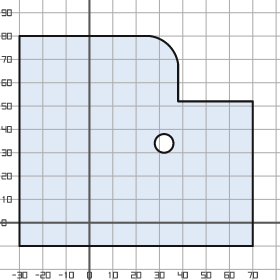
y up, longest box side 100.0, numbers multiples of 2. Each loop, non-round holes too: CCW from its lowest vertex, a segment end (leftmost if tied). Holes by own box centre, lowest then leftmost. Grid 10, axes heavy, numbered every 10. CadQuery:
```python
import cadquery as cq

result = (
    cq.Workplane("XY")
    .moveTo(-30.0, -10.0)
    .lineTo(70.0, -10.0)
    .lineTo(70.0, 52.0)
    .lineTo(38.0, 52.0)
    .lineTo(38.0, 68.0)
    .threePointArc((34.0, 76.0), (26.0, 80.0))
    .lineTo(-30.0, 80.0)
    .close()
    .moveTo(32.0, 34.0)
    .circle(4.0)
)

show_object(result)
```